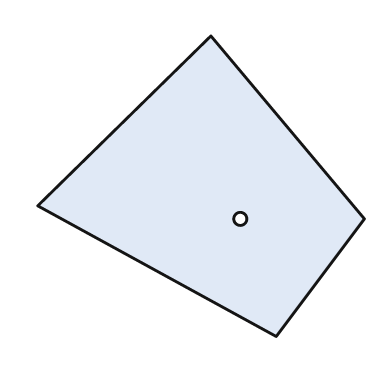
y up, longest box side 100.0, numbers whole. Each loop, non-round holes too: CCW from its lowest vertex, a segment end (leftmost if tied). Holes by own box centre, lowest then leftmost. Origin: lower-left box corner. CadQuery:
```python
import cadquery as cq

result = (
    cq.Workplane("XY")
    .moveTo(73.0, 0.0)
    .lineTo(100.0, 36.0)
    .lineTo(53.0, 92.0)
    .lineTo(0.0, 40.0)
    .close()
    .moveTo(62.0, 36.0)
    .circle(2.0)
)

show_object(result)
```